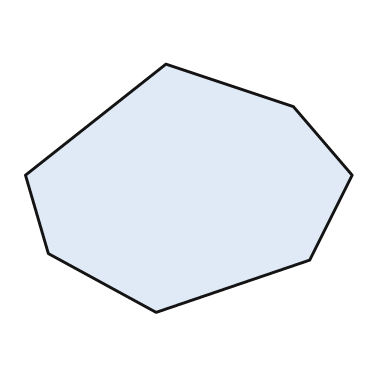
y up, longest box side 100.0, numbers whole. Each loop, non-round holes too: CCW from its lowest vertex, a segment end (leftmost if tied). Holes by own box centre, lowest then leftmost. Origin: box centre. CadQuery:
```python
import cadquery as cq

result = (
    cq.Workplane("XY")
    .moveTo(-10.0, -38.0)
    .lineTo(37.0, -22.0)
    .lineTo(50.0, 4.0)
    .lineTo(32.0, 25.0)
    .lineTo(-7.0, 38.0)
    .lineTo(-50.0, 4.0)
    .lineTo(-43.0, -20.0)
    .close()
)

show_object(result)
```